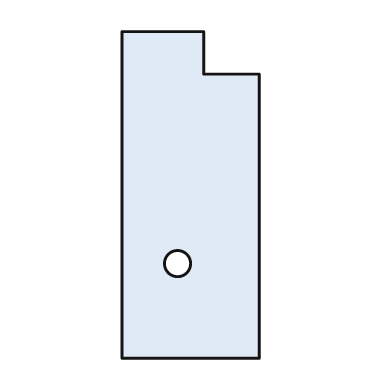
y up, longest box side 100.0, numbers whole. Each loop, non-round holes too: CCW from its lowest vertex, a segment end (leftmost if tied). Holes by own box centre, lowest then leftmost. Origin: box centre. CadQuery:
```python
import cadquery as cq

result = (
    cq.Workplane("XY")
    .moveTo(-21.0, -50.0)
    .lineTo(21.0, -50.0)
    .lineTo(21.0, 37.0)
    .lineTo(4.0, 37.0)
    .lineTo(4.0, 50.0)
    .lineTo(-21.0, 50.0)
    .close()
    .moveTo(-4.0, -21.0)
    .circle(4.0)
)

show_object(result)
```